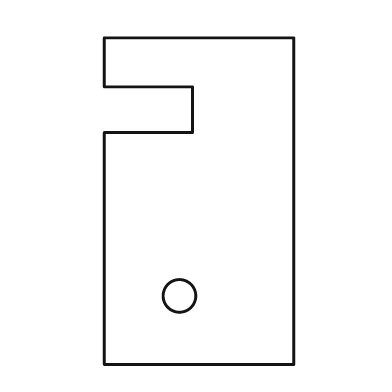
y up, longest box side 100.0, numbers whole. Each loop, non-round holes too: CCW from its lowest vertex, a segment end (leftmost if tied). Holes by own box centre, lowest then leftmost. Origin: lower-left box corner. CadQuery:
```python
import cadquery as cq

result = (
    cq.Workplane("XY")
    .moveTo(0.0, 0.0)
    .lineTo(58.0, 0.0)
    .lineTo(58.0, 100.0)
    .lineTo(0.0, 100.0)
    .lineTo(0.0, 85.0)
    .lineTo(27.0, 85.0)
    .lineTo(27.0, 71.0)
    .lineTo(0.0, 71.0)
    .close()
    .moveTo(23.0, 21.0)
    .circle(5.0)
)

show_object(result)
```